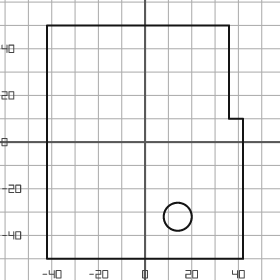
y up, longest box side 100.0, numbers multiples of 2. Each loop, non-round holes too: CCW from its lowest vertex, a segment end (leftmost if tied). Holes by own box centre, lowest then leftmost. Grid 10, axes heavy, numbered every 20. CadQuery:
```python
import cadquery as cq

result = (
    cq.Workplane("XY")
    .moveTo(-42.0, -50.0)
    .lineTo(42.0, -50.0)
    .lineTo(42.0, 10.0)
    .lineTo(36.0, 10.0)
    .lineTo(36.0, 50.0)
    .lineTo(-42.0, 50.0)
    .close()
    .moveTo(14.0, -32.0)
    .circle(6.0)
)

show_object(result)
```